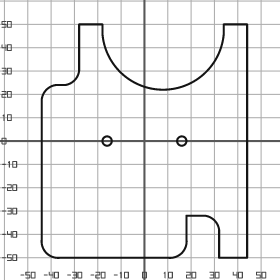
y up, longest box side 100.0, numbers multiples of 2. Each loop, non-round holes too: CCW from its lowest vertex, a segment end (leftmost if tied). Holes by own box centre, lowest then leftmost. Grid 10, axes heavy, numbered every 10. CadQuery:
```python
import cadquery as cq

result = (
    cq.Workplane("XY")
    .moveTo(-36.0, -50.0)
    .lineTo(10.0, -50.0)
    .threePointArc((16.0, -48.0), (18.0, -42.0))
    .lineTo(18.0, -32.0)
    .lineTo(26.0, -32.0)
    .threePointArc((30.0, -34.0), (32.0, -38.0))
    .lineTo(32.0, -50.0)
    .lineTo(44.0, -50.0)
    .lineTo(44.0, 50.0)
    .lineTo(34.0, 50.0)
    .lineTo(34.0, 46.0)
    .threePointArc((8.0, 22.0), (-18.0, 46.0))
    .lineTo(-18.0, 50.0)
    .lineTo(-28.0, 50.0)
    .lineTo(-28.0, 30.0)
    .threePointArc((-30.0, 26.0), (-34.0, 24.0))
    .lineTo(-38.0, 24.0)
    .threePointArc((-42.0, 22.0), (-44.0, 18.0))
    .lineTo(-44.0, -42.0)
    .threePointArc((-42.0, -48.0), (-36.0, -50.0))
    .close()
    .moveTo(-16.0, 0.0)
    .circle(2.0)
    .moveTo(16.0, 0.0)
    .circle(2.0)
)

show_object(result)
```